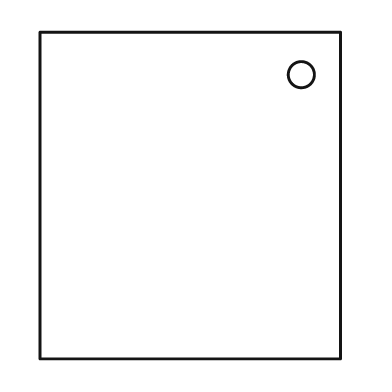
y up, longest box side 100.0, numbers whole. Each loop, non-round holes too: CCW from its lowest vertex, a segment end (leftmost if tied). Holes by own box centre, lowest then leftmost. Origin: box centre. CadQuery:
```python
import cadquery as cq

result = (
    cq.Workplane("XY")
    .moveTo(-46.0, -50.0)
    .lineTo(46.0, -50.0)
    .lineTo(46.0, 50.0)
    .lineTo(-46.0, 50.0)
    .close()
    .moveTo(34.0, 37.0)
    .circle(4.0)
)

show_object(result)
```